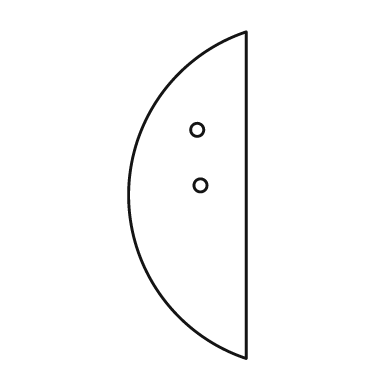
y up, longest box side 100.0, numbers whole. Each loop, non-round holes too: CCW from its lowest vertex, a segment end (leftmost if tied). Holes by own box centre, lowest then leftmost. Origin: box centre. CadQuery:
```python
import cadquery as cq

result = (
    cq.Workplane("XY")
    .moveTo(18.0, -50.0)
    .lineTo(18.0, 50.0)
    .threePointArc((-18.0, 0.0), (18.0, -50.0))
    .close()
    .moveTo(4.0, 3.0)
    .circle(2.0)
    .moveTo(3.0, 20.0)
    .circle(2.0)
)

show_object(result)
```